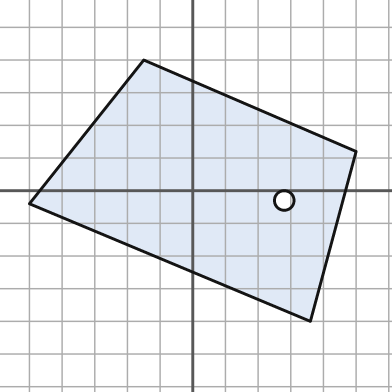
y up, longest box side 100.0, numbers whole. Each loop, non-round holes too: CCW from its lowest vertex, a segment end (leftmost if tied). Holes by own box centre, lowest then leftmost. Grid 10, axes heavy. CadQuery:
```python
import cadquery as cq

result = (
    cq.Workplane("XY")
    .moveTo(36.0, -40.0)
    .lineTo(50.0, 12.0)
    .lineTo(-15.0, 40.0)
    .lineTo(-50.0, -4.0)
    .close()
    .moveTo(28.0, -3.0)
    .circle(3.0)
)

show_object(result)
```